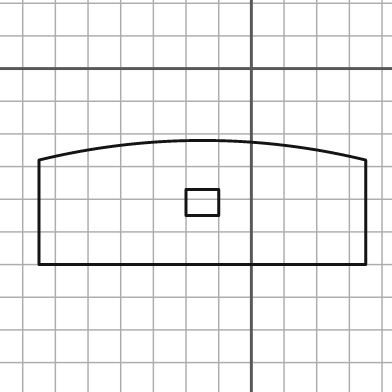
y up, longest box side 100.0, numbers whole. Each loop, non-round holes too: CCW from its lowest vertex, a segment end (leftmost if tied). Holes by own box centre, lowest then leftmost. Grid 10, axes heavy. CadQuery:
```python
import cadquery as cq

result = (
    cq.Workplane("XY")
    .moveTo(-65.0, -60.0)
    .lineTo(35.0, -60.0)
    .lineTo(35.0, -28.0)
    .threePointArc((-15.0, -22.0), (-65.0, -28.0))
    .close()
    .moveTo(-20.0, -45.0)
    .lineTo(-10.0, -45.0)
    .lineTo(-10.0, -37.0)
    .lineTo(-20.0, -37.0)
    .close()
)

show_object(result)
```